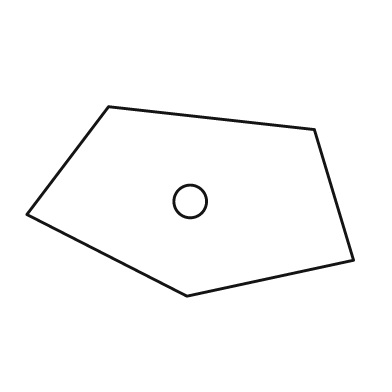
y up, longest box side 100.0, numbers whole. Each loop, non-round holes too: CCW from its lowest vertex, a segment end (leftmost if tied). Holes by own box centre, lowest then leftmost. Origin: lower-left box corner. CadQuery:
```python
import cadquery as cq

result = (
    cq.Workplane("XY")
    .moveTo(49.0, 0.0)
    .lineTo(100.0, 11.0)
    .lineTo(88.0, 51.0)
    .lineTo(25.0, 58.0)
    .lineTo(0.0, 25.0)
    .close()
    .moveTo(50.0, 29.0)
    .circle(5.0)
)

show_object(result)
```